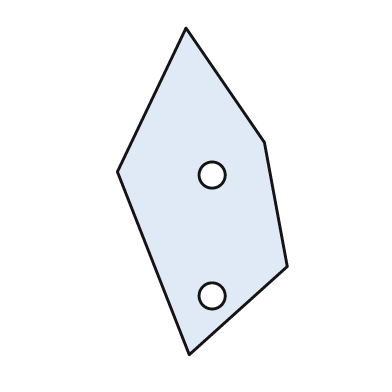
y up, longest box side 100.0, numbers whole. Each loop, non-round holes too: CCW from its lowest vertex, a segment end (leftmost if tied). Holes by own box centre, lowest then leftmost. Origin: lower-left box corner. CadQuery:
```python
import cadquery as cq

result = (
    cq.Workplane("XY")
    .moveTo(22.0, 0.0)
    .lineTo(52.0, 27.0)
    .lineTo(45.0, 65.0)
    .lineTo(21.0, 100.0)
    .lineTo(0.0, 56.0)
    .close()
    .moveTo(29.0, 18.0)
    .circle(4.0)
    .moveTo(29.0, 55.0)
    .circle(4.0)
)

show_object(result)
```